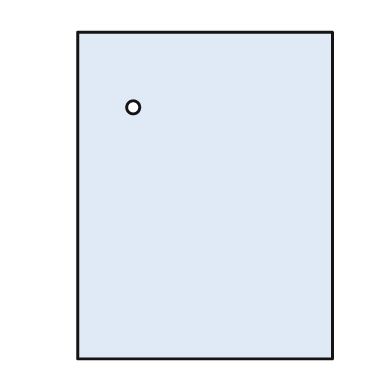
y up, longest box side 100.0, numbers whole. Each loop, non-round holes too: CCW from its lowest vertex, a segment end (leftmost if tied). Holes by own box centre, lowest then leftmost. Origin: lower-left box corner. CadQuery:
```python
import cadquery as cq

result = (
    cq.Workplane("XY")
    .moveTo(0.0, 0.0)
    .lineTo(78.0, 0.0)
    .lineTo(78.0, 100.0)
    .lineTo(0.0, 100.0)
    .close()
    .moveTo(17.0, 77.0)
    .circle(2.0)
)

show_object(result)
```